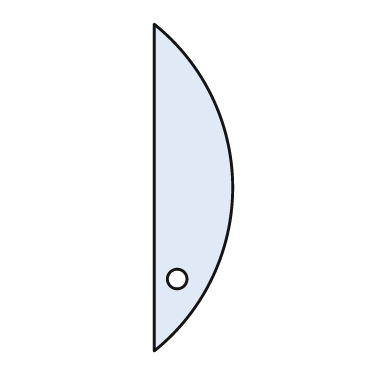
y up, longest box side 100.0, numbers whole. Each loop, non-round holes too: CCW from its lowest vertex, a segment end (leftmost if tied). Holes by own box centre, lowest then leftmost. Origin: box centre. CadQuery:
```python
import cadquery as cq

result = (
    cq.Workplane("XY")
    .moveTo(-12.0, -50.0)
    .threePointArc((12.0, 0.0), (-12.0, 50.0))
    .close()
    .moveTo(-5.0, -28.0)
    .circle(3.0)
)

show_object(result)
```